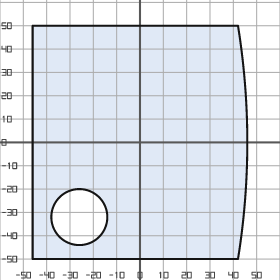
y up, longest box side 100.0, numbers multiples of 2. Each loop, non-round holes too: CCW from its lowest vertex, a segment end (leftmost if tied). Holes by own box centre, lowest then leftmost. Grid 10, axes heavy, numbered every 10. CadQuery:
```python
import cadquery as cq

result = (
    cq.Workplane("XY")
    .moveTo(-46.0, -50.0)
    .lineTo(42.0, -50.0)
    .threePointArc((46.0, 0.0), (42.0, 50.0))
    .lineTo(-46.0, 50.0)
    .close()
    .moveTo(-26.0, -32.0)
    .circle(12.0)
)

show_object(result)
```